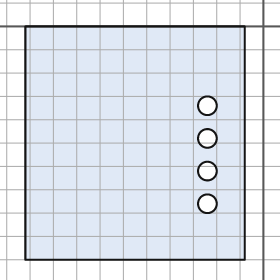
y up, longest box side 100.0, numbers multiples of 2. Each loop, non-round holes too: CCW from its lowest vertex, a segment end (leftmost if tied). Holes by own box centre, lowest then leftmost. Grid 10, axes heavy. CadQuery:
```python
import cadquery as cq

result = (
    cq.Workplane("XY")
    .moveTo(-102.0, -100.0)
    .lineTo(-8.0, -100.0)
    .lineTo(-8.0, 0.0)
    .lineTo(-102.0, 0.0)
    .close()
    .moveTo(-24.0, -76.0)
    .circle(4.0)
    .moveTo(-24.0, -62.0)
    .circle(4.0)
    .moveTo(-24.0, -48.0)
    .circle(4.0)
    .moveTo(-24.0, -34.0)
    .circle(4.0)
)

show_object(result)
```